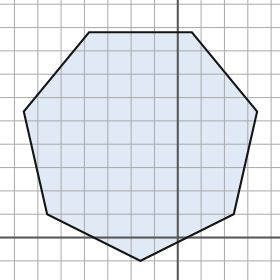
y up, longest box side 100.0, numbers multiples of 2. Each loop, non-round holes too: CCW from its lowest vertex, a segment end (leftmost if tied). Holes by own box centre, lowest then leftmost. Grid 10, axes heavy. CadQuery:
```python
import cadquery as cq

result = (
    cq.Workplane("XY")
    .moveTo(-16.0, -10.0)
    .lineTo(24.0, 10.0)
    .lineTo(34.0, 54.0)
    .lineTo(6.0, 88.0)
    .lineTo(-38.0, 88.0)
    .lineTo(-66.0, 54.0)
    .lineTo(-56.0, 10.0)
    .close()
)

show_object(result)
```